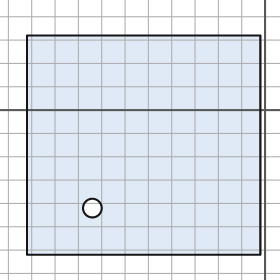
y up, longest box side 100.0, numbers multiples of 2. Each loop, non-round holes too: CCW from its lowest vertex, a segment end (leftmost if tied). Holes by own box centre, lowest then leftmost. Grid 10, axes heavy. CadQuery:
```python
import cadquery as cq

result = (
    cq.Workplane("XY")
    .moveTo(-102.0, -62.0)
    .lineTo(-2.0, -62.0)
    .lineTo(-2.0, 32.0)
    .lineTo(-102.0, 32.0)
    .close()
    .moveTo(-74.0, -42.0)
    .circle(4.0)
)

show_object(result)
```